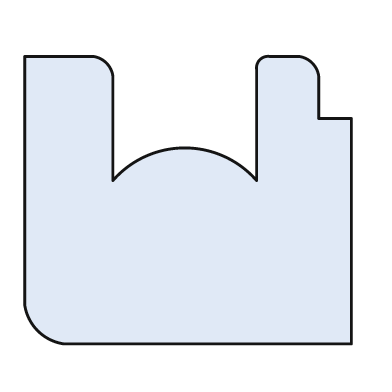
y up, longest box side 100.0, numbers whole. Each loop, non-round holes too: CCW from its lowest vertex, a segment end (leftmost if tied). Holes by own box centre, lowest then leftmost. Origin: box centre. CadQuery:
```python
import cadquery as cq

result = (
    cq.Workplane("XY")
    .moveTo(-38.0, -44.0)
    .lineTo(50.0, -44.0)
    .lineTo(50.0, 25.0)
    .lineTo(40.0, 25.0)
    .lineTo(40.0, 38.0)
    .threePointArc((38.0, 42.0), (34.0, 44.0))
    .lineTo(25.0, 44.0)
    .threePointArc((22.0, 43.0), (21.0, 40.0))
    .lineTo(21.0, 6.0)
    .threePointArc((-1.0, 16.0), (-23.0, 6.0))
    .lineTo(-23.0, 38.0)
    .threePointArc((-25.0, 42.0), (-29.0, 44.0))
    .lineTo(-50.0, 44.0)
    .lineTo(-50.0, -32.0)
    .threePointArc((-46.0, -40.0), (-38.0, -44.0))
    .close()
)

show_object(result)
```